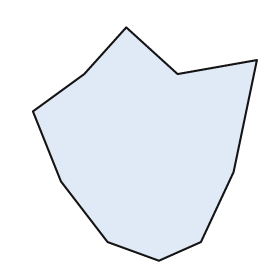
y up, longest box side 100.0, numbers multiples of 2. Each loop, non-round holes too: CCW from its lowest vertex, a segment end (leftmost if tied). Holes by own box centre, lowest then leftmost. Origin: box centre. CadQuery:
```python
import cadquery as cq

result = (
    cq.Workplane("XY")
    .moveTo(6.0, -50.0)
    .lineTo(24.0, -42.0)
    .lineTo(38.0, -12.0)
    .lineTo(48.0, 36.0)
    .lineTo(14.0, 30.0)
    .lineTo(-8.0, 50.0)
    .lineTo(-26.0, 30.0)
    .lineTo(-48.0, 14.0)
    .lineTo(-36.0, -16.0)
    .lineTo(-16.0, -42.0)
    .close()
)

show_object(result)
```